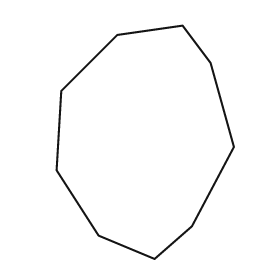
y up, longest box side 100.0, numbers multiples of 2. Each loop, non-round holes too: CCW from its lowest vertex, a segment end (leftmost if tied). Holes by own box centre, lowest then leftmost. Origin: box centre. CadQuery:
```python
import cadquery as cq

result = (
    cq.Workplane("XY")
    .moveTo(4.0, -50.0)
    .lineTo(20.0, -36.0)
    .lineTo(38.0, -2.0)
    .lineTo(28.0, 34.0)
    .lineTo(16.0, 50.0)
    .lineTo(-12.0, 46.0)
    .lineTo(-36.0, 22.0)
    .lineTo(-38.0, -12.0)
    .lineTo(-20.0, -40.0)
    .close()
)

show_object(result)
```